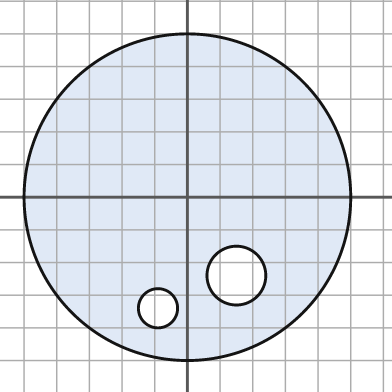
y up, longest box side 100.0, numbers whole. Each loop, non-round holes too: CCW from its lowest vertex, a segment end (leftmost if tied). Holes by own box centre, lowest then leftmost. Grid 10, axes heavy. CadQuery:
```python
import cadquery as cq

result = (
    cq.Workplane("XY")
    .moveTo(0.0, 0.0)
    .circle(50.0)
    .moveTo(-9.0, -34.0)
    .circle(6.0)
    .moveTo(15.0, -24.0)
    .circle(9.0)
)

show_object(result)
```